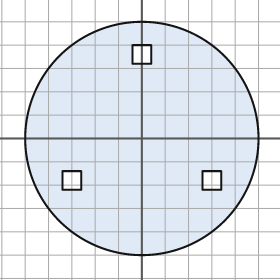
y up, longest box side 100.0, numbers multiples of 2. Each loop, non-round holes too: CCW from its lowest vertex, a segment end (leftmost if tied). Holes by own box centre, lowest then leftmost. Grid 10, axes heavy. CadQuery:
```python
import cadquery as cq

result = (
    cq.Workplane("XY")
    .moveTo(0.0, 0.0)
    .circle(50.0)
    .moveTo(-34.0, -22.0)
    .lineTo(-26.0, -22.0)
    .lineTo(-26.0, -14.0)
    .lineTo(-34.0, -14.0)
    .close()
    .moveTo(26.0, -22.0)
    .lineTo(34.0, -22.0)
    .lineTo(34.0, -14.0)
    .lineTo(26.0, -14.0)
    .close()
    .moveTo(-4.0, 32.0)
    .lineTo(4.0, 32.0)
    .lineTo(4.0, 40.0)
    .lineTo(-4.0, 40.0)
    .close()
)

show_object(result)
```